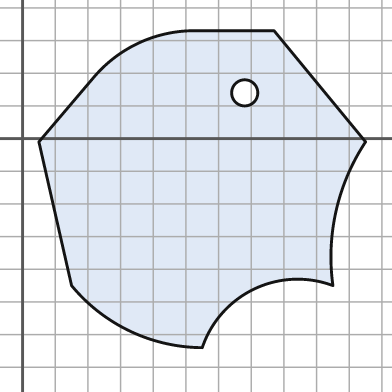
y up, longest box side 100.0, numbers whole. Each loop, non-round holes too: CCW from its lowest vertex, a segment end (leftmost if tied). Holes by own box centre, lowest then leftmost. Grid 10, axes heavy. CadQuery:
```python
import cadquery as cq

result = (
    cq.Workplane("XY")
    .moveTo(55.0, -64.0)
    .threePointArc((71.0, -46.0), (95.0, -45.0))
    .threePointArc((96.0, -22.0), (105.0, -1.0))
    .lineTo(77.0, 33.0)
    .lineTo(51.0, 33.0)
    .threePointArc((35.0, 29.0), (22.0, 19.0))
    .lineTo(5.0, -1.0)
    .lineTo(15.0, -45.0)
    .threePointArc((33.0, -59.0), (55.0, -64.0))
    .close()
    .moveTo(68.0, 14.0)
    .circle(4.0)
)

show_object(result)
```